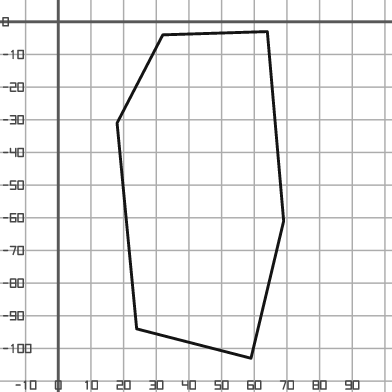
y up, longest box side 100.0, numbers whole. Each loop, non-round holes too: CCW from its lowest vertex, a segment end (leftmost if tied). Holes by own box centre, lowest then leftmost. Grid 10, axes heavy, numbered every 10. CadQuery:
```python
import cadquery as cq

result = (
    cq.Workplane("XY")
    .moveTo(59.0, -103.0)
    .lineTo(69.0, -61.0)
    .lineTo(64.0, -3.0)
    .lineTo(32.0, -4.0)
    .lineTo(18.0, -31.0)
    .lineTo(24.0, -94.0)
    .close()
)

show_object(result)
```